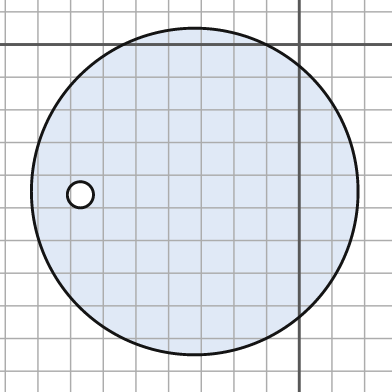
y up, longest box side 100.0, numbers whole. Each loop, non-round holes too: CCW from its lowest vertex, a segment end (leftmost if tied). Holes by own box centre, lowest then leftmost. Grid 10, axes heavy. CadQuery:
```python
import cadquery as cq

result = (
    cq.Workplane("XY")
    .moveTo(-32.0, -45.0)
    .circle(50.0)
    .moveTo(-67.0, -46.0)
    .circle(4.0)
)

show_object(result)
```